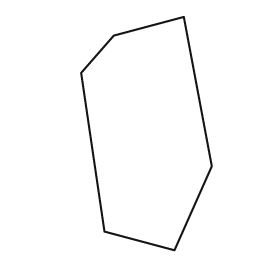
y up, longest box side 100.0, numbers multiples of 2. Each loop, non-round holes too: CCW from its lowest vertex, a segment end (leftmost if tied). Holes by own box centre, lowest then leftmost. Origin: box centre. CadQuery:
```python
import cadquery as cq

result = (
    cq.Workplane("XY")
    .moveTo(12.0, -50.0)
    .lineTo(28.0, -14.0)
    .lineTo(16.0, 50.0)
    .lineTo(-14.0, 42.0)
    .lineTo(-28.0, 26.0)
    .lineTo(-18.0, -42.0)
    .close()
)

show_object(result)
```